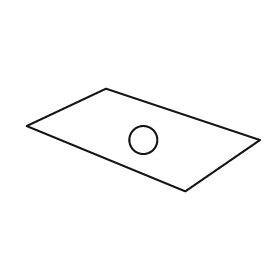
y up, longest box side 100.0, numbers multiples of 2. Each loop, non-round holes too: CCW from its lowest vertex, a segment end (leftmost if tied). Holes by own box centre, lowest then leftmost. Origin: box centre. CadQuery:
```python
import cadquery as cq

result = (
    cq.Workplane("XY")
    .moveTo(18.0, -22.0)
    .lineTo(50.0, 0.0)
    .lineTo(-16.0, 22.0)
    .lineTo(-50.0, 6.0)
    .close()
    .moveTo(0.0, 0.0)
    .circle(6.0)
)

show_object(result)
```